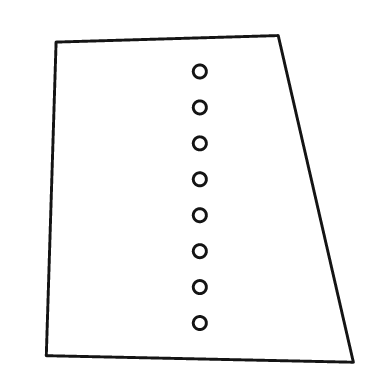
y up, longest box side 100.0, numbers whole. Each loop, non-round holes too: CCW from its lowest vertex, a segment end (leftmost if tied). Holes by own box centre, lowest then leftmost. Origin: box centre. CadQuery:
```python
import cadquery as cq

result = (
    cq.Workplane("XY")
    .moveTo(47.0, -50.0)
    .lineTo(24.0, 50.0)
    .lineTo(-44.0, 48.0)
    .lineTo(-47.0, -48.0)
    .close()
    .moveTo(0.0, -38.0)
    .circle(2.0)
    .moveTo(0.0, -27.0)
    .circle(2.0)
    .moveTo(0.0, -16.0)
    .circle(2.0)
    .moveTo(0.0, -5.0)
    .circle(2.0)
    .moveTo(0.0, 6.0)
    .circle(2.0)
    .moveTo(0.0, 17.0)
    .circle(2.0)
    .moveTo(0.0, 28.0)
    .circle(2.0)
    .moveTo(0.0, 39.0)
    .circle(2.0)
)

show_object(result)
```